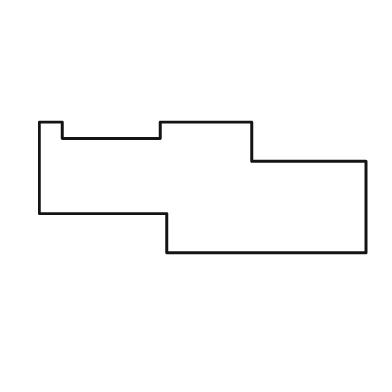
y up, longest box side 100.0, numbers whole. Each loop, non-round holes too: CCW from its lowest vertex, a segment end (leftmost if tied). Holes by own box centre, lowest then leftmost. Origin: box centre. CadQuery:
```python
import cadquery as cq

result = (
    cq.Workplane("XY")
    .moveTo(-11.0, -20.0)
    .lineTo(50.0, -20.0)
    .lineTo(50.0, 8.0)
    .lineTo(15.0, 8.0)
    .lineTo(15.0, 20.0)
    .lineTo(-13.0, 20.0)
    .lineTo(-13.0, 15.0)
    .lineTo(-43.0, 15.0)
    .lineTo(-43.0, 20.0)
    .lineTo(-50.0, 20.0)
    .lineTo(-50.0, -8.0)
    .lineTo(-11.0, -8.0)
    .close()
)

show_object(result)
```